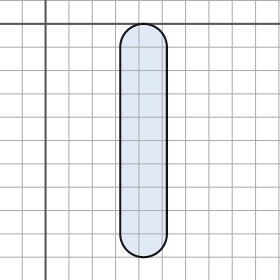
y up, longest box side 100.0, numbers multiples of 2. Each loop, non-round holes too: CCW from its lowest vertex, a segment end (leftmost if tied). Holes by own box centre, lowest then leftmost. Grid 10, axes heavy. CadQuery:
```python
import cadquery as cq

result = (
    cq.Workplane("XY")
    .moveTo(32.0, -90.0)
    .threePointArc((42.0, -100.0), (52.0, -90.0))
    .lineTo(52.0, -10.0)
    .threePointArc((42.0, 0.0), (32.0, -10.0))
    .close()
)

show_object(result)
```